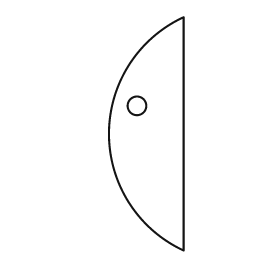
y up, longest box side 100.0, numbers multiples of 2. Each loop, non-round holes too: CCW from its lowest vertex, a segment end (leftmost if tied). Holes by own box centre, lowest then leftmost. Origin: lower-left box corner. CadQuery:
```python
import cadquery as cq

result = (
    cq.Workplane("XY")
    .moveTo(32.0, 0.0)
    .lineTo(32.0, 100.0)
    .threePointArc((0.0, 50.0), (32.0, 0.0))
    .close()
    .moveTo(12.0, 62.0)
    .circle(4.0)
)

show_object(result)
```